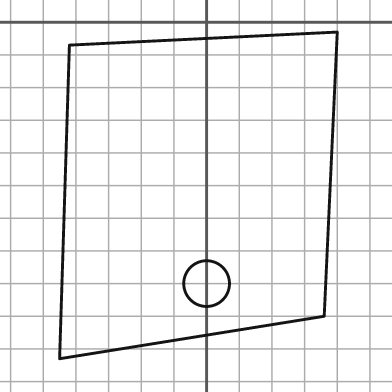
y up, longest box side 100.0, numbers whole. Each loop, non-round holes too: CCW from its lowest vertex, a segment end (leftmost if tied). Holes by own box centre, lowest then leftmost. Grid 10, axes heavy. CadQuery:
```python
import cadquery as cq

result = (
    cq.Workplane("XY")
    .moveTo(-45.0, -103.0)
    .lineTo(36.0, -90.0)
    .lineTo(40.0, -3.0)
    .lineTo(-42.0, -7.0)
    .close()
    .moveTo(0.0, -80.0)
    .circle(7.0)
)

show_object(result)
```